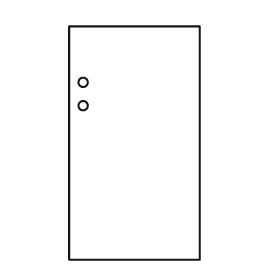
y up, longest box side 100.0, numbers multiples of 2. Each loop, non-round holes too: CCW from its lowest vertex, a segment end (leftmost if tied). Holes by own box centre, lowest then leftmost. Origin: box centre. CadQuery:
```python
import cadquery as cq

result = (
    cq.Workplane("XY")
    .moveTo(-28.0, -50.0)
    .lineTo(28.0, -50.0)
    .lineTo(28.0, 50.0)
    .lineTo(-28.0, 50.0)
    .close()
    .moveTo(-22.0, 16.0)
    .circle(2.0)
    .moveTo(-22.0, 26.0)
    .circle(2.0)
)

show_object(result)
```